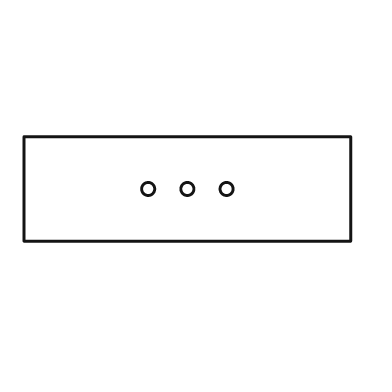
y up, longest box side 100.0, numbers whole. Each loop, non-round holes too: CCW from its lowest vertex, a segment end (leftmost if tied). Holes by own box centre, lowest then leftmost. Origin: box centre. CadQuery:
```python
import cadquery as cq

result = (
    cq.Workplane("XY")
    .moveTo(-50.0, -16.0)
    .lineTo(50.0, -16.0)
    .lineTo(50.0, 16.0)
    .lineTo(-50.0, 16.0)
    .close()
    .moveTo(-12.0, 0.0)
    .circle(2.0)
    .moveTo(0.0, 0.0)
    .circle(2.0)
    .moveTo(12.0, 0.0)
    .circle(2.0)
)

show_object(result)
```